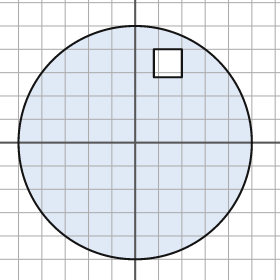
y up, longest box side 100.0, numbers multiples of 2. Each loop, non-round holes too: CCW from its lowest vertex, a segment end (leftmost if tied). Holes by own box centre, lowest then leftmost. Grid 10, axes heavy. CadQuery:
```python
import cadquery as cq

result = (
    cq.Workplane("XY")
    .moveTo(0.0, 0.0)
    .circle(50.0)
    .moveTo(8.0, 28.0)
    .lineTo(20.0, 28.0)
    .lineTo(20.0, 40.0)
    .lineTo(8.0, 40.0)
    .close()
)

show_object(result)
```